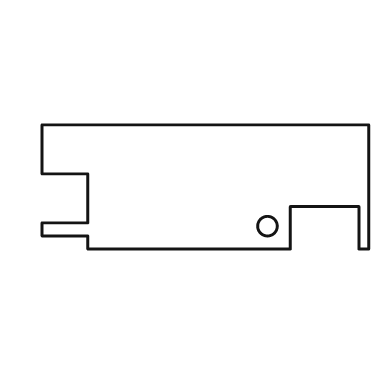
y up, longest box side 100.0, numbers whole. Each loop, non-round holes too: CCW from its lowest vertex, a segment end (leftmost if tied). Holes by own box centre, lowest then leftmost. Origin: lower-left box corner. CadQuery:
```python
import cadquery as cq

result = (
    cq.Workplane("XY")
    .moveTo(14.0, 0.0)
    .lineTo(76.0, 0.0)
    .lineTo(76.0, 13.0)
    .lineTo(97.0, 13.0)
    .lineTo(97.0, 0.0)
    .lineTo(100.0, 0.0)
    .lineTo(100.0, 38.0)
    .lineTo(0.0, 38.0)
    .lineTo(0.0, 23.0)
    .lineTo(14.0, 23.0)
    .lineTo(14.0, 8.0)
    .lineTo(0.0, 8.0)
    .lineTo(0.0, 4.0)
    .lineTo(14.0, 4.0)
    .close()
    .moveTo(69.0, 7.0)
    .circle(3.0)
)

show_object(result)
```